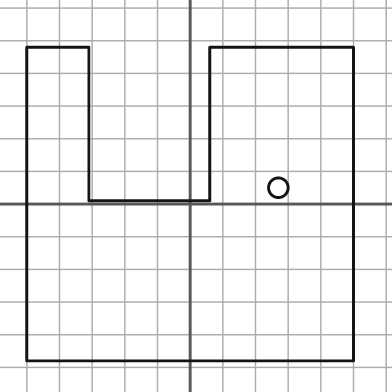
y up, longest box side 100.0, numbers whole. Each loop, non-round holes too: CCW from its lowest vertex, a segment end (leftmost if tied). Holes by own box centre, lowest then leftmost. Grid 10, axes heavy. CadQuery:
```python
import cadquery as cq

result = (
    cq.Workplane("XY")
    .moveTo(-50.0, -48.0)
    .lineTo(50.0, -48.0)
    .lineTo(50.0, 48.0)
    .lineTo(6.0, 48.0)
    .lineTo(6.0, 1.0)
    .lineTo(-31.0, 1.0)
    .lineTo(-31.0, 48.0)
    .lineTo(-50.0, 48.0)
    .close()
    .moveTo(27.0, 5.0)
    .circle(3.0)
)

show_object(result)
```